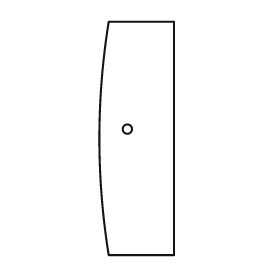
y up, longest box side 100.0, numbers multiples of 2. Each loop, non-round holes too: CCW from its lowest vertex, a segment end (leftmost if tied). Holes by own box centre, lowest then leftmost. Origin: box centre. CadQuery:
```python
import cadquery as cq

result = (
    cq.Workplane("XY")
    .moveTo(-12.0, -50.0)
    .lineTo(16.0, -50.0)
    .lineTo(16.0, 50.0)
    .lineTo(-12.0, 50.0)
    .threePointArc((-16.0, 0.0), (-12.0, -50.0))
    .close()
    .moveTo(-4.0, 4.0)
    .circle(2.0)
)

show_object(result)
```